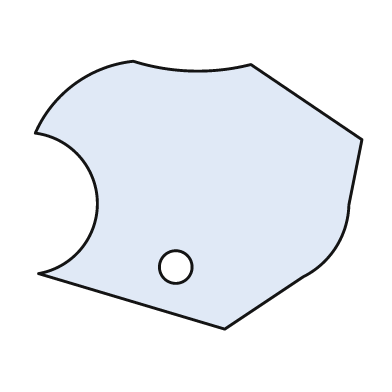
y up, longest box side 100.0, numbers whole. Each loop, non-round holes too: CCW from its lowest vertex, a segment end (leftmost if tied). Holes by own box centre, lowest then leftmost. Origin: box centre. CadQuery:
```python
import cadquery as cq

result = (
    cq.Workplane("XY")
    .moveTo(8.0, -41.0)
    .lineTo(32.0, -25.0)
    .threePointArc((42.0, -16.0), (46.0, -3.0))
    .lineTo(50.0, 17.0)
    .lineTo(16.0, 40.0)
    .threePointArc((-2.0, 38.0), (-20.0, 41.0))
    .threePointArc((-38.0, 34.0), (-50.0, 19.0))
    .threePointArc((-31.0, -2.0), (-49.0, -24.0))
    .close()
    .moveTo(-7.0, -22.0)
    .circle(5.0)
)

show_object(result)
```